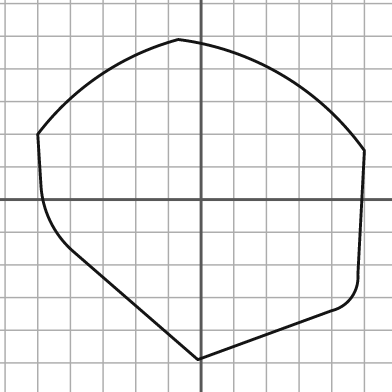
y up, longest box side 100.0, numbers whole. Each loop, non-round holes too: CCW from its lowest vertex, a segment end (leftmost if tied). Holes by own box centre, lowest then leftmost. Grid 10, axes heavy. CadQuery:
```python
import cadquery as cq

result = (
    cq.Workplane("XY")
    .moveTo(-1.0, -49.0)
    .lineTo(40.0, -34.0)
    .threePointArc((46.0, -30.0), (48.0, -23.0))
    .lineTo(50.0, 15.0)
    .threePointArc((25.0, 38.0), (-7.0, 49.0))
    .threePointArc((-31.0, 38.0), (-50.0, 20.0))
    .lineTo(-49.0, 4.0)
    .threePointArc((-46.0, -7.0), (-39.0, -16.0))
    .close()
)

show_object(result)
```